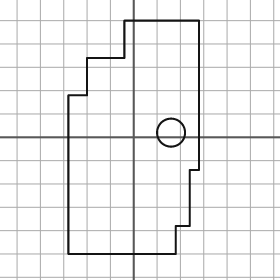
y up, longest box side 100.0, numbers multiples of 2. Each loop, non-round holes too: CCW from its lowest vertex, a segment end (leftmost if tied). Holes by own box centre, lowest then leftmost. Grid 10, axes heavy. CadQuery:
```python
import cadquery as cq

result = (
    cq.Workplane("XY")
    .moveTo(-28.0, -50.0)
    .lineTo(18.0, -50.0)
    .lineTo(18.0, -38.0)
    .lineTo(24.0, -38.0)
    .lineTo(24.0, -14.0)
    .lineTo(28.0, -14.0)
    .lineTo(28.0, 50.0)
    .lineTo(-4.0, 50.0)
    .lineTo(-4.0, 34.0)
    .lineTo(-20.0, 34.0)
    .lineTo(-20.0, 18.0)
    .lineTo(-28.0, 18.0)
    .close()
    .moveTo(16.0, 2.0)
    .circle(6.0)
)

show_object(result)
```